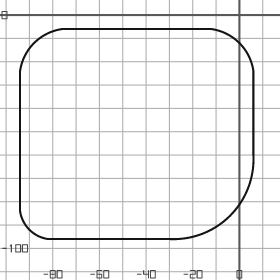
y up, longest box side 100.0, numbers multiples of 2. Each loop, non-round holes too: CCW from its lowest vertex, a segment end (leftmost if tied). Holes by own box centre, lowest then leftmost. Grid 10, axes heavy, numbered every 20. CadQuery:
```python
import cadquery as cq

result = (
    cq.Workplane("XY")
    .moveTo(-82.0, -96.0)
    .lineTo(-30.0, -96.0)
    .threePointArc((-4.0, -86.0), (6.0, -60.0))
    .lineTo(6.0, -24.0)
    .threePointArc((0.0, -12.0), (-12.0, -6.0))
    .lineTo(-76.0, -6.0)
    .threePointArc((-88.0, -12.0), (-94.0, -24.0))
    .lineTo(-94.0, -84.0)
    .threePointArc((-90.0, -92.0), (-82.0, -96.0))
    .close()
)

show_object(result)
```